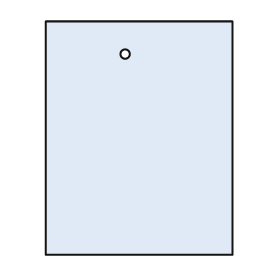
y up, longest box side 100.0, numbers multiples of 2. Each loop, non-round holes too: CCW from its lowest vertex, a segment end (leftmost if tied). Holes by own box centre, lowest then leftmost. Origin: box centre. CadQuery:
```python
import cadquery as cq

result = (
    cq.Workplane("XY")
    .moveTo(-40.0, -50.0)
    .lineTo(40.0, -50.0)
    .lineTo(40.0, 50.0)
    .lineTo(-40.0, 50.0)
    .close()
    .moveTo(-6.0, 36.0)
    .circle(2.0)
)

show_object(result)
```